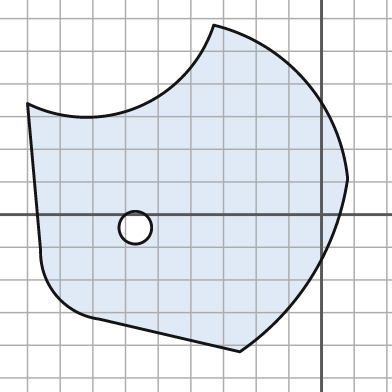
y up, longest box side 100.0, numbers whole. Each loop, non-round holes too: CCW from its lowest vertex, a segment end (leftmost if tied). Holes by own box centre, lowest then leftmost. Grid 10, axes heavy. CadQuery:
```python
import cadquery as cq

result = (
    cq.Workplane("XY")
    .moveTo(-25.0, -42.0)
    .threePointArc((-3.0, -19.0), (8.0, 11.0))
    .threePointArc((-5.0, 41.0), (-33.0, 58.0))
    .threePointArc((-56.0, 33.0), (-90.0, 34.0))
    .lineTo(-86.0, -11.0)
    .threePointArc((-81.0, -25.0), (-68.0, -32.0))
    .close()
    .moveTo(-57.0, -4.0)
    .circle(5.0)
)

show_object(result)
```